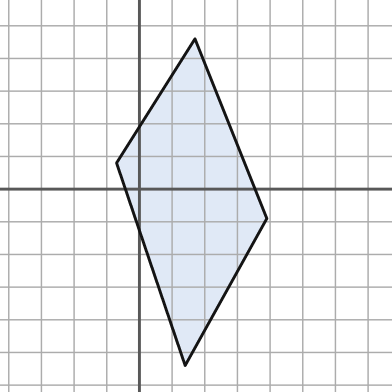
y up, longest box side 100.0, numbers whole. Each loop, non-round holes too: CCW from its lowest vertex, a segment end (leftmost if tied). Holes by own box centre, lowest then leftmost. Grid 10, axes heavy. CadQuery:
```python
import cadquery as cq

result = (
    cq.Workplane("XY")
    .moveTo(14.0, -54.0)
    .lineTo(39.0, -9.0)
    .lineTo(17.0, 46.0)
    .lineTo(-7.0, 8.0)
    .close()
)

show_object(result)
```